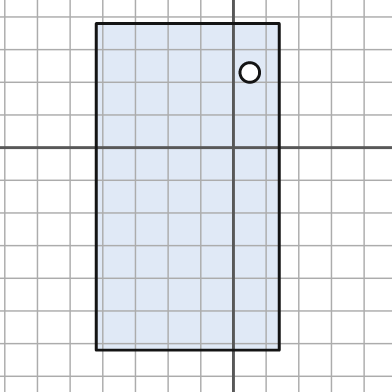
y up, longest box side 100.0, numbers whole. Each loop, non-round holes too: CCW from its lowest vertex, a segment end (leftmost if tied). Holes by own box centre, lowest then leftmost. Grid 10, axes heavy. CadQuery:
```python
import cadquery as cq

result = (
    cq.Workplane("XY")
    .moveTo(-42.0, -62.0)
    .lineTo(14.0, -62.0)
    .lineTo(14.0, 38.0)
    .lineTo(-42.0, 38.0)
    .close()
    .moveTo(5.0, 23.0)
    .circle(3.0)
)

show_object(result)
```